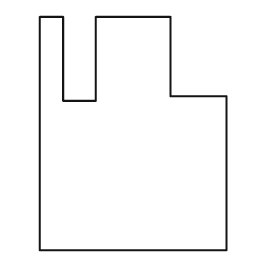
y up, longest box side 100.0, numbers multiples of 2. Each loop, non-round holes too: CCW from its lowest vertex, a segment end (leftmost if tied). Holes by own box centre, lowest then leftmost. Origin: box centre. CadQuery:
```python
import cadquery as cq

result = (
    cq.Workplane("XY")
    .moveTo(-40.0, -50.0)
    .lineTo(40.0, -50.0)
    .lineTo(40.0, 16.0)
    .lineTo(16.0, 16.0)
    .lineTo(16.0, 50.0)
    .lineTo(-16.0, 50.0)
    .lineTo(-16.0, 14.0)
    .lineTo(-30.0, 14.0)
    .lineTo(-30.0, 50.0)
    .lineTo(-40.0, 50.0)
    .close()
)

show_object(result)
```